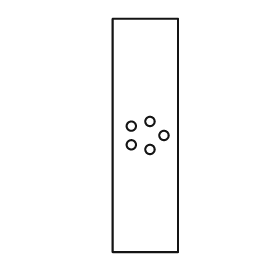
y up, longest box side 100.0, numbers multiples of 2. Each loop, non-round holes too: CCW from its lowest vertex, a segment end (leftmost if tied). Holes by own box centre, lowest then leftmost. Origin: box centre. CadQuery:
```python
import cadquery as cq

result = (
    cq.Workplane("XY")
    .moveTo(-14.0, -50.0)
    .lineTo(14.0, -50.0)
    .lineTo(14.0, 50.0)
    .lineTo(-14.0, 50.0)
    .close()
    .moveTo(2.0, -6.0)
    .circle(2.0)
    .moveTo(-6.0, -4.0)
    .circle(2.0)
    .moveTo(8.0, 0.0)
    .circle(2.0)
    .moveTo(-6.0, 4.0)
    .circle(2.0)
    .moveTo(2.0, 6.0)
    .circle(2.0)
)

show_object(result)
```